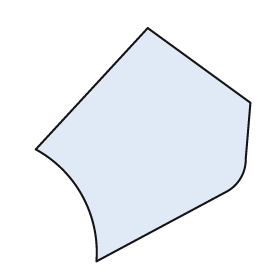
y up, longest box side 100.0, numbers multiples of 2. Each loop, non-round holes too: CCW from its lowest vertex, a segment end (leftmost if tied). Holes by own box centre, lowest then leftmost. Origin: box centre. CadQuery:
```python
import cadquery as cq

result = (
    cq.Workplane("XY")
    .moveTo(-20.0, -50.0)
    .lineTo(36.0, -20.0)
    .threePointArc((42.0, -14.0), (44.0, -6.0))
    .lineTo(46.0, 18.0)
    .lineTo(2.0, 50.0)
    .lineTo(-46.0, -2.0)
    .threePointArc((-26.0, -22.0), (-20.0, -50.0))
    .close()
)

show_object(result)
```